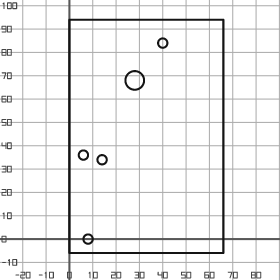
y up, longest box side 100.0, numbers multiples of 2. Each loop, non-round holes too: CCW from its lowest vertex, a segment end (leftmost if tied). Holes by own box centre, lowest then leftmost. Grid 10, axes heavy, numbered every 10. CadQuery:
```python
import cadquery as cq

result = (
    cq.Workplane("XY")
    .moveTo(0.0, -6.0)
    .lineTo(66.0, -6.0)
    .lineTo(66.0, 94.0)
    .lineTo(0.0, 94.0)
    .close()
    .moveTo(8.0, 0.0)
    .circle(2.0)
    .moveTo(14.0, 34.0)
    .circle(2.0)
    .moveTo(6.0, 36.0)
    .circle(2.0)
    .moveTo(28.0, 68.0)
    .circle(4.0)
    .moveTo(40.0, 84.0)
    .circle(2.0)
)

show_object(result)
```